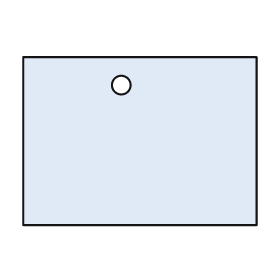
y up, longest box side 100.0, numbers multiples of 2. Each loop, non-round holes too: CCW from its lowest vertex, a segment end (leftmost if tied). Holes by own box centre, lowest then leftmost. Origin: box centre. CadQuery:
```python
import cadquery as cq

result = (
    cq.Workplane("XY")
    .moveTo(-50.0, -36.0)
    .lineTo(50.0, -36.0)
    .lineTo(50.0, 36.0)
    .lineTo(-50.0, 36.0)
    .close()
    .moveTo(-8.0, 24.0)
    .circle(4.0)
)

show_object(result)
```